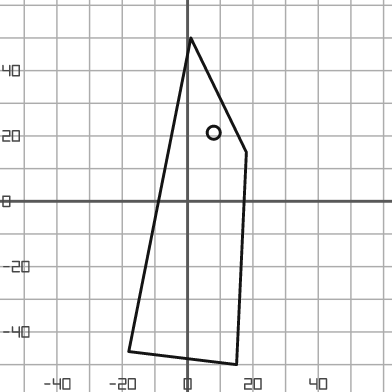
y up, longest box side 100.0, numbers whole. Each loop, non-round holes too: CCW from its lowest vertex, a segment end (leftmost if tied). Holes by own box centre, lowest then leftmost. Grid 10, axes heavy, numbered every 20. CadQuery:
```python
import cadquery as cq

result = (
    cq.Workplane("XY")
    .moveTo(15.0, -50.0)
    .lineTo(18.0, 15.0)
    .lineTo(1.0, 50.0)
    .lineTo(-18.0, -46.0)
    .close()
    .moveTo(8.0, 21.0)
    .circle(2.0)
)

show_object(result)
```